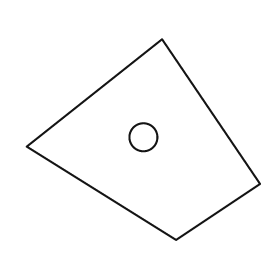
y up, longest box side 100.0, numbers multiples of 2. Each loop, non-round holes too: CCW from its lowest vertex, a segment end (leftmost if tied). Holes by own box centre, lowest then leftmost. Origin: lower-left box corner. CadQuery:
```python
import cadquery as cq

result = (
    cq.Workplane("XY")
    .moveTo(64.0, 0.0)
    .lineTo(100.0, 24.0)
    .lineTo(58.0, 86.0)
    .lineTo(0.0, 40.0)
    .close()
    .moveTo(50.0, 44.0)
    .circle(6.0)
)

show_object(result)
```